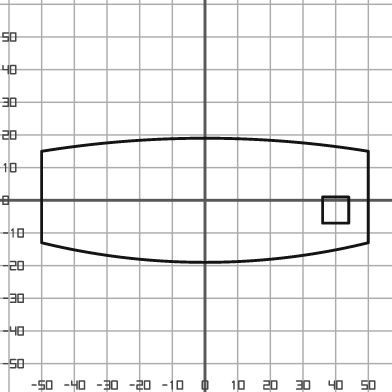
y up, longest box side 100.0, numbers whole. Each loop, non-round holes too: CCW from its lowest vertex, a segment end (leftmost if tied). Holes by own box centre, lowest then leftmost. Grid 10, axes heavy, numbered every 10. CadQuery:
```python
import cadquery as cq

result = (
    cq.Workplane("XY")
    .moveTo(-50.0, -13.0)
    .threePointArc((0.0, -19.0), (50.0, -13.0))
    .lineTo(50.0, 15.0)
    .threePointArc((0.0, 19.0), (-50.0, 15.0))
    .close()
    .moveTo(36.0, -7.0)
    .lineTo(44.0, -7.0)
    .lineTo(44.0, 1.0)
    .lineTo(36.0, 1.0)
    .close()
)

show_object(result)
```